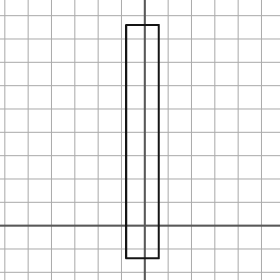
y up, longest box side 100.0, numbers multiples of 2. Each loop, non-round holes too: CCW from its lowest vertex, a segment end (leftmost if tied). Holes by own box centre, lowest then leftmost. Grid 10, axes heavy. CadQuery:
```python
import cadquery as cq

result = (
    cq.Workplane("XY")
    .moveTo(-8.0, -14.0)
    .lineTo(6.0, -14.0)
    .lineTo(6.0, 86.0)
    .lineTo(-8.0, 86.0)
    .close()
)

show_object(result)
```